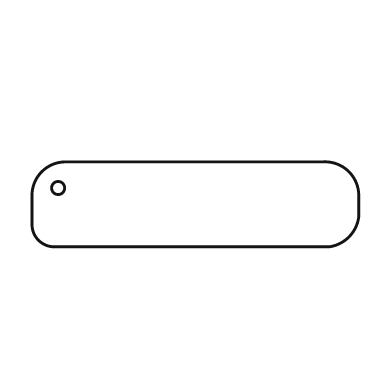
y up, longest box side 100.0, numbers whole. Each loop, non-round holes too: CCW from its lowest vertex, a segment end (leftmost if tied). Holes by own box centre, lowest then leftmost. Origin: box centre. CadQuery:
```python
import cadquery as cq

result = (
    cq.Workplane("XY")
    .moveTo(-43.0, -13.0)
    .lineTo(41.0, -13.0)
    .threePointArc((47.0, -10.0), (50.0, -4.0))
    .lineTo(50.0, 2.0)
    .threePointArc((47.0, 10.0), (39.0, 13.0))
    .lineTo(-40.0, 13.0)
    .threePointArc((-47.0, 10.0), (-50.0, 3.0))
    .lineTo(-50.0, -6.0)
    .threePointArc((-48.0, -11.0), (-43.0, -13.0))
    .close()
    .moveTo(-42.0, 5.0)
    .circle(2.0)
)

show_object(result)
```